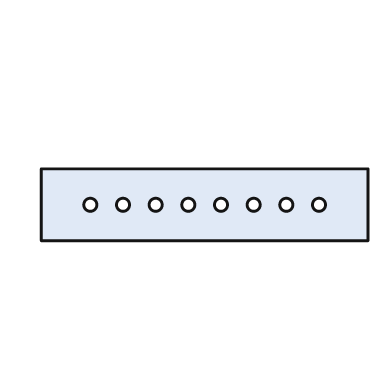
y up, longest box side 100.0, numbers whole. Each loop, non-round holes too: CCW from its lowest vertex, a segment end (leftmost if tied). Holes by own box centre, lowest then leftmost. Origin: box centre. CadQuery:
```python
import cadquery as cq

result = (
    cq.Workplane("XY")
    .moveTo(-50.0, -11.0)
    .lineTo(50.0, -11.0)
    .lineTo(50.0, 11.0)
    .lineTo(-50.0, 11.0)
    .close()
    .moveTo(-35.0, 0.0)
    .circle(2.0)
    .moveTo(-25.0, 0.0)
    .circle(2.0)
    .moveTo(-15.0, 0.0)
    .circle(2.0)
    .moveTo(-5.0, 0.0)
    .circle(2.0)
    .moveTo(5.0, 0.0)
    .circle(2.0)
    .moveTo(15.0, 0.0)
    .circle(2.0)
    .moveTo(25.0, 0.0)
    .circle(2.0)
    .moveTo(35.0, 0.0)
    .circle(2.0)
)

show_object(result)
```